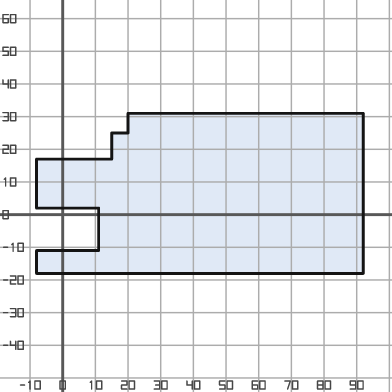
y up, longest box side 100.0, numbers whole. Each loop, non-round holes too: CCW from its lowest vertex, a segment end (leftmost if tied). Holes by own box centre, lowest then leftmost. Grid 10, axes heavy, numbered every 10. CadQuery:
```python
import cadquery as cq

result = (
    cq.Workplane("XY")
    .moveTo(-8.0, -18.0)
    .lineTo(92.0, -18.0)
    .lineTo(92.0, 31.0)
    .lineTo(20.0, 31.0)
    .lineTo(20.0, 25.0)
    .lineTo(15.0, 25.0)
    .lineTo(15.0, 17.0)
    .lineTo(-8.0, 17.0)
    .lineTo(-8.0, 2.0)
    .lineTo(11.0, 2.0)
    .lineTo(11.0, -11.0)
    .lineTo(-8.0, -11.0)
    .close()
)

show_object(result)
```